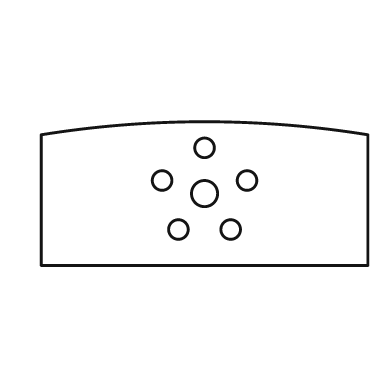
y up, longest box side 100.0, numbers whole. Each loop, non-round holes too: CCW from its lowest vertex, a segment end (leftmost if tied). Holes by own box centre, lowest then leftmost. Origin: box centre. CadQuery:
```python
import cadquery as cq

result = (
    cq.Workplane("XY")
    .moveTo(-50.0, -22.0)
    .lineTo(50.0, -22.0)
    .lineTo(50.0, 18.0)
    .threePointArc((0.0, 22.0), (-50.0, 18.0))
    .close()
    .moveTo(-8.0, -11.0)
    .circle(3.0)
    .moveTo(8.0, -11.0)
    .circle(3.0)
    .moveTo(0.0, 0.0)
    .circle(4.0)
    .moveTo(-13.0, 4.0)
    .circle(3.0)
    .moveTo(13.0, 4.0)
    .circle(3.0)
    .moveTo(0.0, 14.0)
    .circle(3.0)
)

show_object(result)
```